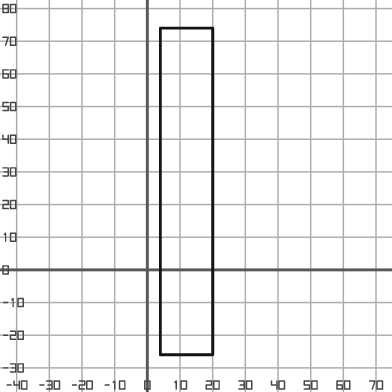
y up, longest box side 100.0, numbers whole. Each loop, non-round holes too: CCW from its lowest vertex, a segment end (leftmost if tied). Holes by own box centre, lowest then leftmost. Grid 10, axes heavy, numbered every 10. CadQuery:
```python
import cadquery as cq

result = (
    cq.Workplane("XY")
    .moveTo(4.0, -26.0)
    .lineTo(20.0, -26.0)
    .lineTo(20.0, 74.0)
    .lineTo(4.0, 74.0)
    .close()
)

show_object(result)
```